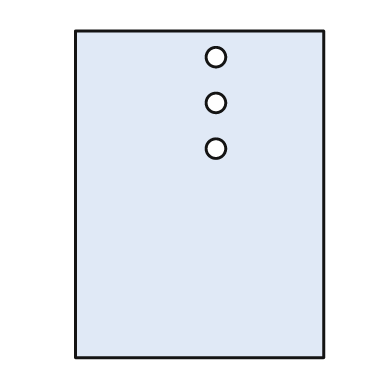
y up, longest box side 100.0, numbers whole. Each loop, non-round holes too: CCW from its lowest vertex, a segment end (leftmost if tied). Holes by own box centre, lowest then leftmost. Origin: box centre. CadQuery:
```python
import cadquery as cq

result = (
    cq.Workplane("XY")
    .moveTo(-38.0, -50.0)
    .lineTo(38.0, -50.0)
    .lineTo(38.0, 50.0)
    .lineTo(-38.0, 50.0)
    .close()
    .moveTo(5.0, 14.0)
    .circle(3.0)
    .moveTo(5.0, 28.0)
    .circle(3.0)
    .moveTo(5.0, 42.0)
    .circle(3.0)
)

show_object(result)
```